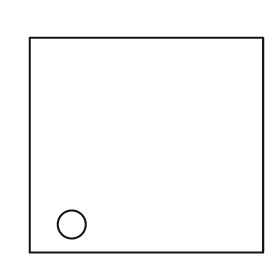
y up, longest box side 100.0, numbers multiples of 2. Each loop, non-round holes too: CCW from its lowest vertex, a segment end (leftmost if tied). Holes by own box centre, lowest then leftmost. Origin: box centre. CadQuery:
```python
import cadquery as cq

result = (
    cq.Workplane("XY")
    .moveTo(-50.0, -46.0)
    .lineTo(50.0, -46.0)
    .lineTo(50.0, 46.0)
    .lineTo(-50.0, 46.0)
    .close()
    .moveTo(-32.0, -34.0)
    .circle(6.0)
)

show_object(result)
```